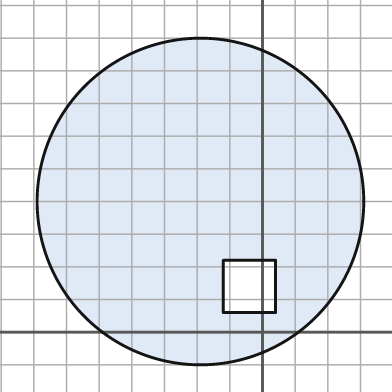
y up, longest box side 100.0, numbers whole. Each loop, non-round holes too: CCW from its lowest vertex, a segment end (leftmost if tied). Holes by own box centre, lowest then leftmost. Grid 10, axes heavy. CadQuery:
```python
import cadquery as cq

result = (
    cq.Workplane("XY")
    .moveTo(-19.0, 40.0)
    .circle(50.0)
    .moveTo(-12.0, 6.0)
    .lineTo(4.0, 6.0)
    .lineTo(4.0, 22.0)
    .lineTo(-12.0, 22.0)
    .close()
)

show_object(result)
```